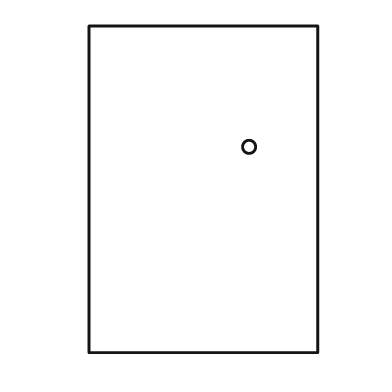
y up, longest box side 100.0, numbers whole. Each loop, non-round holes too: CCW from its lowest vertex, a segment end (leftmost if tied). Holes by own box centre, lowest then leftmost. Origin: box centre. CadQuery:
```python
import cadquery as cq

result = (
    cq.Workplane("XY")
    .moveTo(-35.0, -50.0)
    .lineTo(35.0, -50.0)
    .lineTo(35.0, 50.0)
    .lineTo(-35.0, 50.0)
    .close()
    .moveTo(14.0, 13.0)
    .circle(2.0)
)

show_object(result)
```